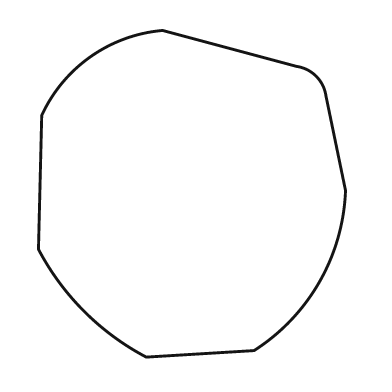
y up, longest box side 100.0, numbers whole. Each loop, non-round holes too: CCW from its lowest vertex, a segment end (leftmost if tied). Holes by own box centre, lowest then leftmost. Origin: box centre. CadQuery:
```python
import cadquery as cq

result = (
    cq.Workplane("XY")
    .moveTo(-14.0, -50.0)
    .lineTo(19.0, -48.0)
    .threePointArc((39.0, -27.0), (47.0, 1.0))
    .lineTo(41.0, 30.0)
    .threePointArc((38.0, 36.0), (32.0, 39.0))
    .lineTo(-9.0, 50.0)
    .threePointArc((-31.0, 42.0), (-46.0, 24.0))
    .lineTo(-47.0, -17.0)
    .threePointArc((-33.0, -36.0), (-14.0, -50.0))
    .close()
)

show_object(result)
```